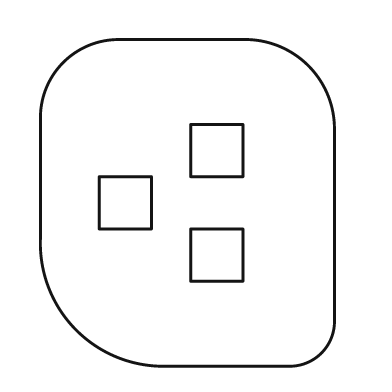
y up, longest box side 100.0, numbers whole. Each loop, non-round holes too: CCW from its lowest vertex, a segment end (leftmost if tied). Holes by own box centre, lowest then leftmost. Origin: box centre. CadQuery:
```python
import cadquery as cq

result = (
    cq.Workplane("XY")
    .moveTo(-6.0, -50.0)
    .lineTo(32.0, -50.0)
    .threePointArc((41.0, -46.0), (45.0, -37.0))
    .lineTo(45.0, 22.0)
    .threePointArc((37.0, 42.0), (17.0, 50.0))
    .lineTo(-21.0, 50.0)
    .threePointArc((-38.0, 43.0), (-45.0, 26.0))
    .lineTo(-45.0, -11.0)
    .threePointArc((-34.0, -39.0), (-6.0, -50.0))
    .close()
    .moveTo(1.0, -24.0)
    .lineTo(17.0, -24.0)
    .lineTo(17.0, -8.0)
    .lineTo(1.0, -8.0)
    .close()
    .moveTo(-27.0, -8.0)
    .lineTo(-11.0, -8.0)
    .lineTo(-11.0, 8.0)
    .lineTo(-27.0, 8.0)
    .close()
    .moveTo(1.0, 8.0)
    .lineTo(17.0, 8.0)
    .lineTo(17.0, 24.0)
    .lineTo(1.0, 24.0)
    .close()
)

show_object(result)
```